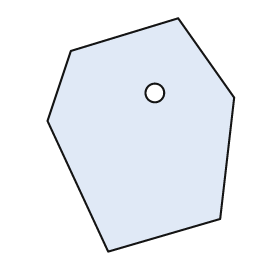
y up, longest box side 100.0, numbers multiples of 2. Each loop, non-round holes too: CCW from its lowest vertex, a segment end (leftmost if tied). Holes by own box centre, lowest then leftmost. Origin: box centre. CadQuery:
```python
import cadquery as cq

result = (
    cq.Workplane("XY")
    .moveTo(-14.0, -50.0)
    .lineTo(34.0, -36.0)
    .lineTo(40.0, 16.0)
    .lineTo(16.0, 50.0)
    .lineTo(-30.0, 36.0)
    .lineTo(-40.0, 6.0)
    .close()
    .moveTo(6.0, 18.0)
    .circle(4.0)
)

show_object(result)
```